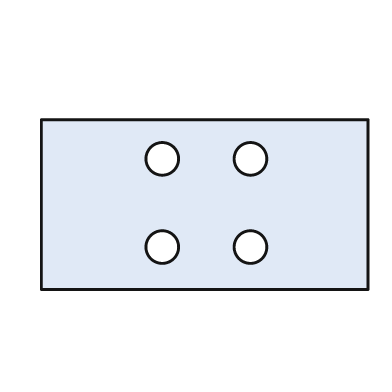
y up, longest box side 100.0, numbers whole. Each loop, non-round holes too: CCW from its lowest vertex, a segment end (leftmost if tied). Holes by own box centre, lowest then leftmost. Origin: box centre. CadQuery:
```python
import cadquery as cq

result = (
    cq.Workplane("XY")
    .moveTo(-50.0, -26.0)
    .lineTo(50.0, -26.0)
    .lineTo(50.0, 26.0)
    .lineTo(-50.0, 26.0)
    .close()
    .moveTo(-13.0, -13.0)
    .circle(5.0)
    .moveTo(14.0, -13.0)
    .circle(5.0)
    .moveTo(-13.0, 14.0)
    .circle(5.0)
    .moveTo(14.0, 14.0)
    .circle(5.0)
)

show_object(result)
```